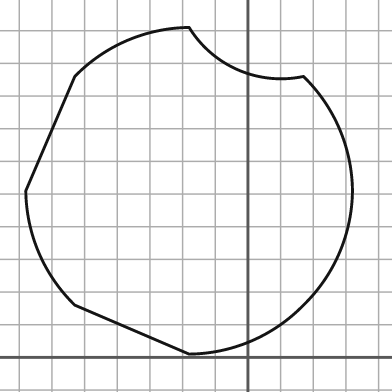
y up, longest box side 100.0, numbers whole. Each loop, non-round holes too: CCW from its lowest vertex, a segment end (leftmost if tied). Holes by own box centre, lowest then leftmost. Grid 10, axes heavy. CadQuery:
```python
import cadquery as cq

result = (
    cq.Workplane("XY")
    .moveTo(-18.0, 1.0)
    .threePointArc((1.0, 5.0), (17.0, 16.0))
    .threePointArc((28.0, 32.0), (32.0, 51.0))
    .threePointArc((28.0, 70.0), (17.0, 86.0))
    .threePointArc((-3.0, 88.0), (-18.0, 101.0))
    .threePointArc((-37.0, 97.0), (-53.0, 86.0))
    .lineTo(-68.0, 51.0)
    .threePointArc((-64.0, 32.0), (-53.0, 16.0))
    .close()
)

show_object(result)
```